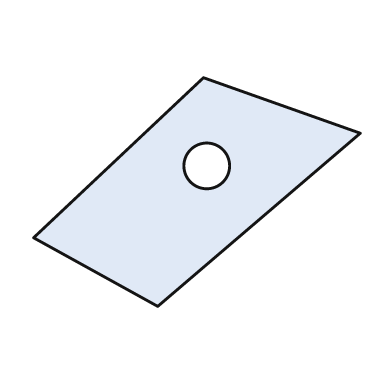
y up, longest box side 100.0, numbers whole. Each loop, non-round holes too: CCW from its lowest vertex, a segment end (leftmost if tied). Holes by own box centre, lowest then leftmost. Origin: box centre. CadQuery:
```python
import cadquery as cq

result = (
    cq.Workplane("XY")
    .moveTo(-12.0, -35.0)
    .lineTo(50.0, 18.0)
    .lineTo(2.0, 35.0)
    .lineTo(-50.0, -14.0)
    .close()
    .moveTo(3.0, 8.0)
    .circle(7.0)
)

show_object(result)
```